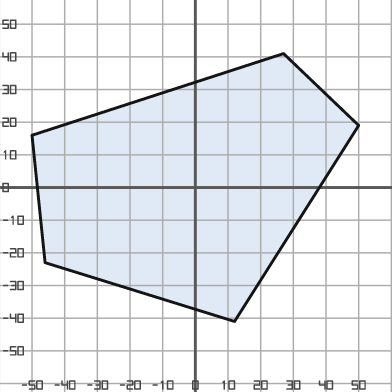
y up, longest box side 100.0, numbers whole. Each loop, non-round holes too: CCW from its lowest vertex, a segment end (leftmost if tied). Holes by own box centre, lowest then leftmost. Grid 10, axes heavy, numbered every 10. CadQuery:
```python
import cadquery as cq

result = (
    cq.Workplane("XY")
    .moveTo(12.0, -41.0)
    .lineTo(50.0, 19.0)
    .lineTo(27.0, 41.0)
    .lineTo(-50.0, 16.0)
    .lineTo(-46.0, -23.0)
    .close()
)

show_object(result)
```